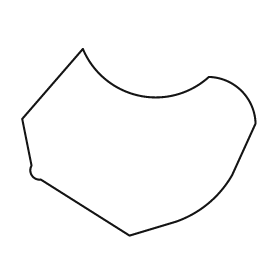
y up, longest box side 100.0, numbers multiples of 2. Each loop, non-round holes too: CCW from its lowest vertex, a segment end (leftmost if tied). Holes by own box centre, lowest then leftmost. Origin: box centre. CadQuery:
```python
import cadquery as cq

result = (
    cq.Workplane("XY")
    .moveTo(-4.0, -40.0)
    .lineTo(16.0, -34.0)
    .threePointArc((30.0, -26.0), (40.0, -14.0))
    .lineTo(50.0, 8.0)
    .threePointArc((44.0, 22.0), (30.0, 28.0))
    .threePointArc((0.0, 20.0), (-24.0, 40.0))
    .lineTo(-50.0, 10.0)
    .lineTo(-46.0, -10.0)
    .threePointArc((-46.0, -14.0), (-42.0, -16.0))
    .close()
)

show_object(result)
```